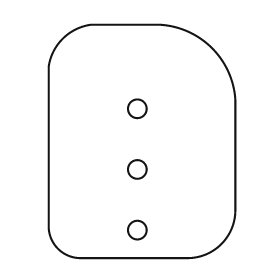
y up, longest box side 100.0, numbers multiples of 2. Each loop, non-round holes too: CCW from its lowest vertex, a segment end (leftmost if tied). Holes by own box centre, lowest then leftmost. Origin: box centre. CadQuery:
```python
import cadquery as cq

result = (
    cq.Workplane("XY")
    .moveTo(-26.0, -50.0)
    .lineTo(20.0, -50.0)
    .threePointArc((34.0, -44.0), (40.0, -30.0))
    .lineTo(40.0, 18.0)
    .threePointArc((30.0, 40.0), (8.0, 50.0))
    .lineTo(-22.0, 50.0)
    .threePointArc((-34.0, 44.0), (-40.0, 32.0))
    .lineTo(-40.0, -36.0)
    .threePointArc((-36.0, -46.0), (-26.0, -50.0))
    .close()
    .moveTo(-2.0, -38.0)
    .circle(4.0)
    .moveTo(-2.0, -12.0)
    .circle(4.0)
    .moveTo(-2.0, 14.0)
    .circle(4.0)
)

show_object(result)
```